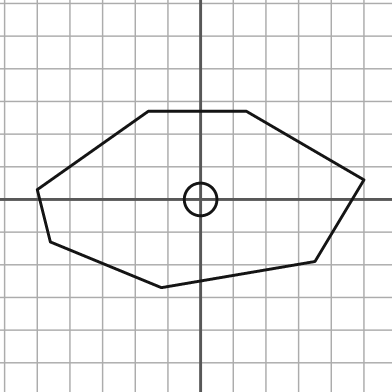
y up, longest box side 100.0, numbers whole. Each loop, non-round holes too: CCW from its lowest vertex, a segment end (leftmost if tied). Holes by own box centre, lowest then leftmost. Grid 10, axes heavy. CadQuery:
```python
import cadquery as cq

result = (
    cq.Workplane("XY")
    .moveTo(-12.0, -27.0)
    .lineTo(35.0, -19.0)
    .lineTo(50.0, 6.0)
    .lineTo(14.0, 27.0)
    .lineTo(-16.0, 27.0)
    .lineTo(-50.0, 3.0)
    .lineTo(-46.0, -13.0)
    .close()
    .moveTo(0.0, 0.0)
    .circle(5.0)
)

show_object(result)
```